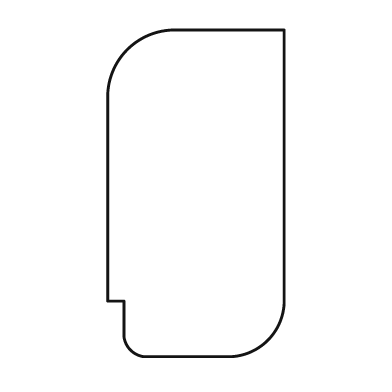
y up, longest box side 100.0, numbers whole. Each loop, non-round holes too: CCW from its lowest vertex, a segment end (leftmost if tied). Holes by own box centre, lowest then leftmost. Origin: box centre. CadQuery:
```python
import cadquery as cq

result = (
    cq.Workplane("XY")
    .moveTo(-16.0, -50.0)
    .lineTo(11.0, -50.0)
    .threePointArc((22.0, -45.0), (27.0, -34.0))
    .lineTo(27.0, 50.0)
    .lineTo(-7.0, 50.0)
    .threePointArc((-21.0, 44.0), (-27.0, 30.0))
    .lineTo(-27.0, -33.0)
    .lineTo(-22.0, -33.0)
    .lineTo(-22.0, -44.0)
    .threePointArc((-20.0, -48.0), (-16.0, -50.0))
    .close()
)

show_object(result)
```